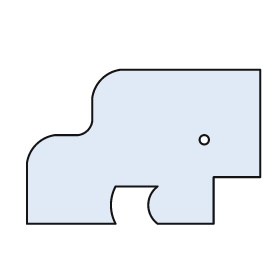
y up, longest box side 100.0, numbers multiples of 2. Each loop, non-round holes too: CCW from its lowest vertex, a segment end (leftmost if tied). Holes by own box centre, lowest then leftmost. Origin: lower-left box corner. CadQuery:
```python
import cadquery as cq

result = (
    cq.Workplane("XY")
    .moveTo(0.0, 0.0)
    .lineTo(38.0, 0.0)
    .threePointArc((36.0, 8.0), (38.0, 16.0))
    .lineTo(56.0, 16.0)
    .threePointArc((52.0, 8.0), (56.0, 0.0))
    .lineTo(80.0, 0.0)
    .lineTo(80.0, 20.0)
    .lineTo(100.0, 20.0)
    .lineTo(100.0, 66.0)
    .lineTo(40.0, 66.0)
    .threePointArc((32.0, 62.0), (28.0, 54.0))
    .lineTo(28.0, 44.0)
    .threePointArc((26.0, 40.0), (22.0, 38.0))
    .lineTo(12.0, 38.0)
    .threePointArc((4.0, 34.0), (0.0, 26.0))
    .close()
    .moveTo(76.0, 36.0)
    .circle(2.0)
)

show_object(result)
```